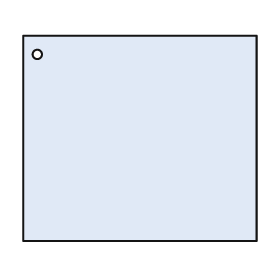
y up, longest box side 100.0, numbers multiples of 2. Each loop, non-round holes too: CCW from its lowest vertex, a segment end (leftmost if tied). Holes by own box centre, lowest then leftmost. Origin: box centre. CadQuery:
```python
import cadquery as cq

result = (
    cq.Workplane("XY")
    .moveTo(-50.0, -44.0)
    .lineTo(50.0, -44.0)
    .lineTo(50.0, 44.0)
    .lineTo(-50.0, 44.0)
    .close()
    .moveTo(-44.0, 36.0)
    .circle(2.0)
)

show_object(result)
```